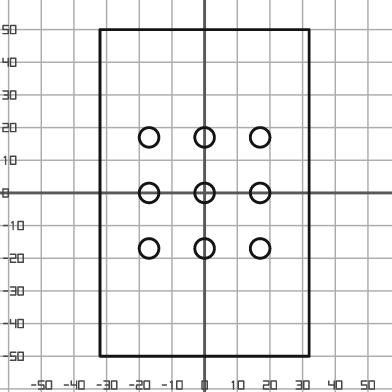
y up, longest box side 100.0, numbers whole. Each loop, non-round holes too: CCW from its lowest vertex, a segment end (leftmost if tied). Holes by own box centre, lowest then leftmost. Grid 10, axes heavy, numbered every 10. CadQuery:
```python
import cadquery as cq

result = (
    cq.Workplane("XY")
    .moveTo(-32.0, -50.0)
    .lineTo(32.0, -50.0)
    .lineTo(32.0, 50.0)
    .lineTo(-32.0, 50.0)
    .close()
    .moveTo(-17.0, -17.0)
    .circle(3.0)
    .moveTo(0.0, -17.0)
    .circle(3.0)
    .moveTo(17.0, -17.0)
    .circle(3.0)
    .moveTo(-17.0, 0.0)
    .circle(3.0)
    .moveTo(0.0, 0.0)
    .circle(3.0)
    .moveTo(17.0, 0.0)
    .circle(3.0)
    .moveTo(-17.0, 17.0)
    .circle(3.0)
    .moveTo(0.0, 17.0)
    .circle(3.0)
    .moveTo(17.0, 17.0)
    .circle(3.0)
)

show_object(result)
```